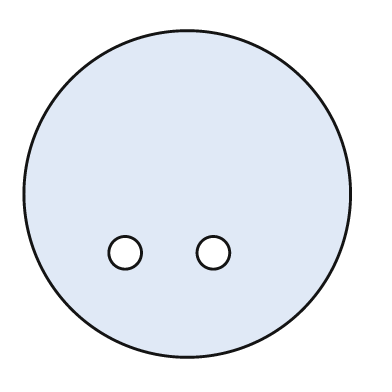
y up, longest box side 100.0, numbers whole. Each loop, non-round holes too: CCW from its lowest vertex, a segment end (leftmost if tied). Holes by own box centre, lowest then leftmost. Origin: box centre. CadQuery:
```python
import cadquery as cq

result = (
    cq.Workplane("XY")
    .moveTo(0.0, 0.0)
    .circle(50.0)
    .moveTo(-19.0, -18.0)
    .circle(5.0)
    .moveTo(8.0, -18.0)
    .circle(5.0)
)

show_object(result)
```